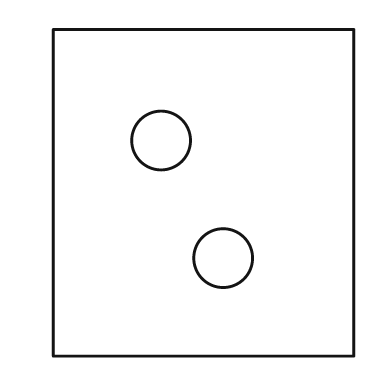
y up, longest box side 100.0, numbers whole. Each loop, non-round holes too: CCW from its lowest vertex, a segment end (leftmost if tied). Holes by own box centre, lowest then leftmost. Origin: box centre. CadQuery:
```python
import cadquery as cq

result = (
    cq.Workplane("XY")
    .moveTo(-46.0, -50.0)
    .lineTo(46.0, -50.0)
    .lineTo(46.0, 50.0)
    .lineTo(-46.0, 50.0)
    .close()
    .moveTo(6.0, -20.0)
    .circle(9.0)
    .moveTo(-13.0, 16.0)
    .circle(9.0)
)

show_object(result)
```